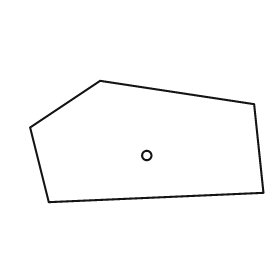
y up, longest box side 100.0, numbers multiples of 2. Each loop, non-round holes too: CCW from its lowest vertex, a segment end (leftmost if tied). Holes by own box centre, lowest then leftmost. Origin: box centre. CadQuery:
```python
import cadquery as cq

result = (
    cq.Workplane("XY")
    .moveTo(-42.0, -26.0)
    .lineTo(50.0, -22.0)
    .lineTo(46.0, 16.0)
    .lineTo(-20.0, 26.0)
    .lineTo(-50.0, 6.0)
    .close()
    .moveTo(0.0, -6.0)
    .circle(2.0)
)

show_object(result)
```